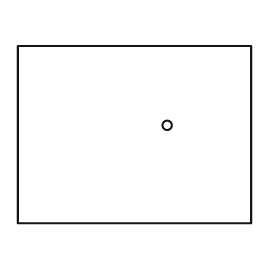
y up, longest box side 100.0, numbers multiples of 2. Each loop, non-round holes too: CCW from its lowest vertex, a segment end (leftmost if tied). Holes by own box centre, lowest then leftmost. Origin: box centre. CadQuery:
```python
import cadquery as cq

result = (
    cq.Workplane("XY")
    .moveTo(-50.0, -38.0)
    .lineTo(50.0, -38.0)
    .lineTo(50.0, 38.0)
    .lineTo(-50.0, 38.0)
    .close()
    .moveTo(14.0, 4.0)
    .circle(2.0)
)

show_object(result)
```